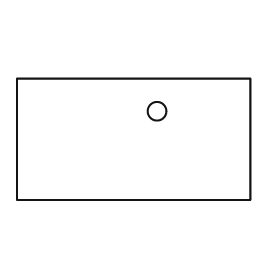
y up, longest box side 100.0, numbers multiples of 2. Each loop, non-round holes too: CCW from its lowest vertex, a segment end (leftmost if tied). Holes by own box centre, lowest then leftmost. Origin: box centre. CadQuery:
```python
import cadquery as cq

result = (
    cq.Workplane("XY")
    .moveTo(-50.0, -26.0)
    .lineTo(50.0, -26.0)
    .lineTo(50.0, 26.0)
    .lineTo(-50.0, 26.0)
    .close()
    .moveTo(10.0, 12.0)
    .circle(4.0)
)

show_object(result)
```